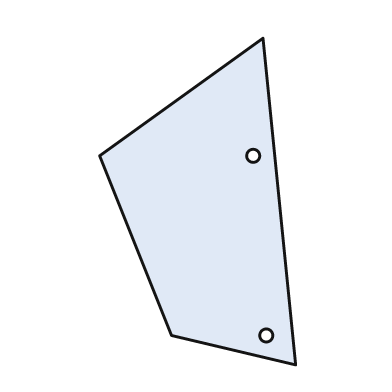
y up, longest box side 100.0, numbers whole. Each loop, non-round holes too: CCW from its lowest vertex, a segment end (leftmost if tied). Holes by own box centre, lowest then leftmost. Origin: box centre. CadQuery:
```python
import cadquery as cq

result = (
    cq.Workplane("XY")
    .moveTo(30.0, -50.0)
    .lineTo(20.0, 50.0)
    .lineTo(-30.0, 14.0)
    .lineTo(-8.0, -41.0)
    .close()
    .moveTo(21.0, -41.0)
    .circle(2.0)
    .moveTo(17.0, 14.0)
    .circle(2.0)
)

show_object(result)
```